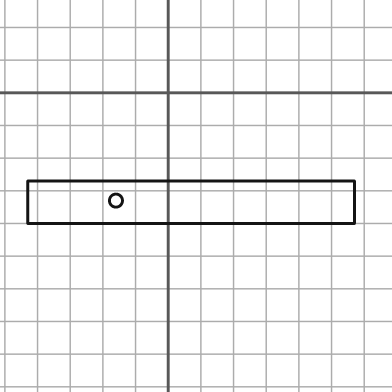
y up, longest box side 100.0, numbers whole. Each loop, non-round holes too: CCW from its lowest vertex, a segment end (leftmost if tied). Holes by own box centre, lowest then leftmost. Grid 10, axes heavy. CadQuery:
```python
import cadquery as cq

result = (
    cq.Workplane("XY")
    .moveTo(-43.0, -40.0)
    .lineTo(57.0, -40.0)
    .lineTo(57.0, -27.0)
    .lineTo(-43.0, -27.0)
    .close()
    .moveTo(-16.0, -33.0)
    .circle(2.0)
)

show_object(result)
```